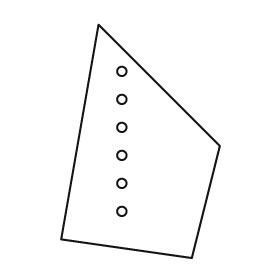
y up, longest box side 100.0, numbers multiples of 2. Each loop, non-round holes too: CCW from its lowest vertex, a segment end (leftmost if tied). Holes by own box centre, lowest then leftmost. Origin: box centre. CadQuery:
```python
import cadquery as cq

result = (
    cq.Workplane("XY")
    .moveTo(22.0, -50.0)
    .lineTo(34.0, -2.0)
    .lineTo(-18.0, 50.0)
    .lineTo(-34.0, -42.0)
    .close()
    .moveTo(-8.0, -30.0)
    .circle(2.0)
    .moveTo(-8.0, -18.0)
    .circle(2.0)
    .moveTo(-8.0, -6.0)
    .circle(2.0)
    .moveTo(-8.0, 6.0)
    .circle(2.0)
    .moveTo(-8.0, 18.0)
    .circle(2.0)
    .moveTo(-8.0, 30.0)
    .circle(2.0)
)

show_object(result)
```